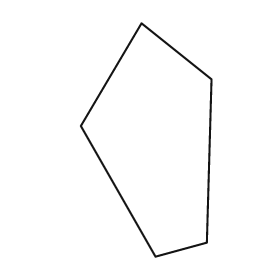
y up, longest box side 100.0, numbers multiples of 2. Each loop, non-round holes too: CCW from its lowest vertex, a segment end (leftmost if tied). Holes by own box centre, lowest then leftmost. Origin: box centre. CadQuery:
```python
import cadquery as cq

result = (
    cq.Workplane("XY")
    .moveTo(4.0, -50.0)
    .lineTo(26.0, -44.0)
    .lineTo(28.0, 26.0)
    .lineTo(-2.0, 50.0)
    .lineTo(-28.0, 6.0)
    .close()
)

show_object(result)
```